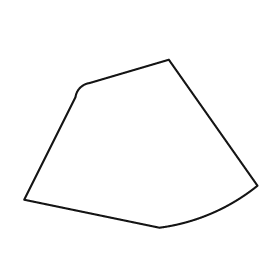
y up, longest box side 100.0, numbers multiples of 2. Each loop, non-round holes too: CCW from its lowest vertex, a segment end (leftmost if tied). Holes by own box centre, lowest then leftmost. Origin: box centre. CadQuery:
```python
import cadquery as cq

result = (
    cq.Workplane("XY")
    .moveTo(8.0, -36.0)
    .threePointArc((30.0, -30.0), (50.0, -18.0))
    .lineTo(12.0, 36.0)
    .lineTo(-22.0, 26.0)
    .threePointArc((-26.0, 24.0), (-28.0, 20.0))
    .lineTo(-50.0, -24.0)
    .close()
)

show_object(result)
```